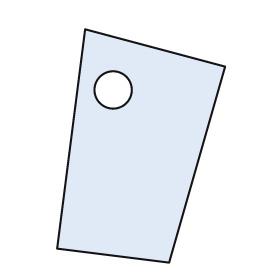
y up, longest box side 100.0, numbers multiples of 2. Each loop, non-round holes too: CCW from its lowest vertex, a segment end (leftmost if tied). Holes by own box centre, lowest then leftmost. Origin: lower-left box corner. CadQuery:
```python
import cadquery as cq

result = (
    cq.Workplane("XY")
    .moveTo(48.0, 0.0)
    .lineTo(72.0, 84.0)
    .lineTo(12.0, 100.0)
    .lineTo(0.0, 6.0)
    .close()
    .moveTo(24.0, 74.0)
    .circle(8.0)
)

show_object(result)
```